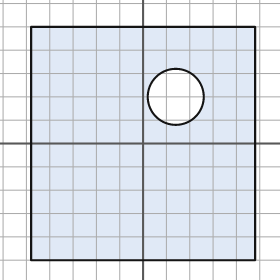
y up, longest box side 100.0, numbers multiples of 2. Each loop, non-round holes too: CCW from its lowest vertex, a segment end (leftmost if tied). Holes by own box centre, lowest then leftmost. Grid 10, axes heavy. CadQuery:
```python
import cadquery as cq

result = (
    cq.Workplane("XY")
    .moveTo(-48.0, -50.0)
    .lineTo(48.0, -50.0)
    .lineTo(48.0, 50.0)
    .lineTo(-48.0, 50.0)
    .close()
    .moveTo(14.0, 20.0)
    .circle(12.0)
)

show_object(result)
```